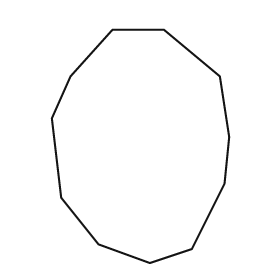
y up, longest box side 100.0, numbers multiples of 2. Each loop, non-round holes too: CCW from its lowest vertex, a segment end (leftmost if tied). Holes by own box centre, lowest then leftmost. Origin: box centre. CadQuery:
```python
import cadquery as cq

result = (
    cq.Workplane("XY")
    .moveTo(4.0, -50.0)
    .lineTo(22.0, -44.0)
    .lineTo(36.0, -16.0)
    .lineTo(38.0, 4.0)
    .lineTo(34.0, 30.0)
    .lineTo(10.0, 50.0)
    .lineTo(-12.0, 50.0)
    .lineTo(-30.0, 30.0)
    .lineTo(-38.0, 12.0)
    .lineTo(-34.0, -22.0)
    .lineTo(-18.0, -42.0)
    .close()
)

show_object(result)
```